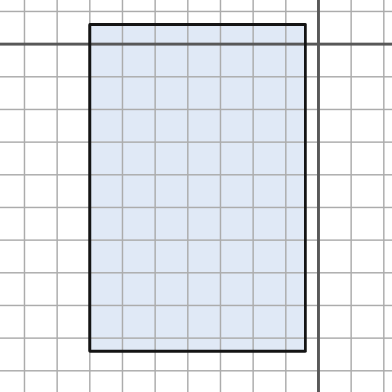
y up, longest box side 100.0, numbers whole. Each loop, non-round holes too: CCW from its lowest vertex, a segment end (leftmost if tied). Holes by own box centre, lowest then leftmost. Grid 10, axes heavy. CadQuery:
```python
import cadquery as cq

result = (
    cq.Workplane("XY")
    .moveTo(-70.0, -94.0)
    .lineTo(-4.0, -94.0)
    .lineTo(-4.0, 6.0)
    .lineTo(-70.0, 6.0)
    .close()
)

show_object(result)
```